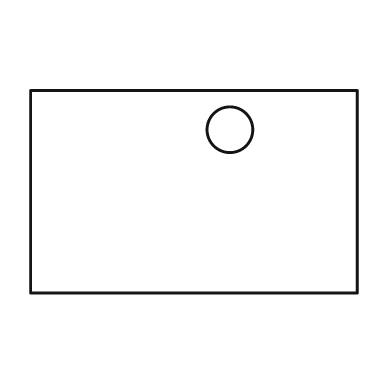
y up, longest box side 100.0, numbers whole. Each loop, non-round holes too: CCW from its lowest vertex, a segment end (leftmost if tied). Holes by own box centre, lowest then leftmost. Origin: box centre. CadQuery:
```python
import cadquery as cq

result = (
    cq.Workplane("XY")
    .moveTo(-50.0, -31.0)
    .lineTo(50.0, -31.0)
    .lineTo(50.0, 31.0)
    .lineTo(-50.0, 31.0)
    .close()
    .moveTo(11.0, 19.0)
    .circle(7.0)
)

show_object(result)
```